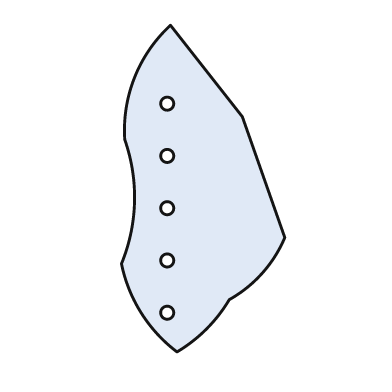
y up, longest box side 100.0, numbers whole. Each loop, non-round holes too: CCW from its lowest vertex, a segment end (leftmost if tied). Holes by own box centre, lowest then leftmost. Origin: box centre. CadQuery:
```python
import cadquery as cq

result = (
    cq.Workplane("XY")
    .moveTo(-8.0, -50.0)
    .threePointArc((1.0, -43.0), (8.0, -34.0))
    .threePointArc((18.0, -26.0), (25.0, -15.0))
    .lineTo(12.0, 22.0)
    .lineTo(-10.0, 50.0)
    .threePointArc((-21.0, 34.0), (-24.0, 15.0))
    .threePointArc((-21.0, -4.0), (-25.0, -23.0))
    .threePointArc((-19.0, -38.0), (-8.0, -50.0))
    .close()
    .moveTo(-11.0, -38.0)
    .circle(2.0)
    .moveTo(-11.0, -22.0)
    .circle(2.0)
    .moveTo(-11.0, -6.0)
    .circle(2.0)
    .moveTo(-11.0, 10.0)
    .circle(2.0)
    .moveTo(-11.0, 26.0)
    .circle(2.0)
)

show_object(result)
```